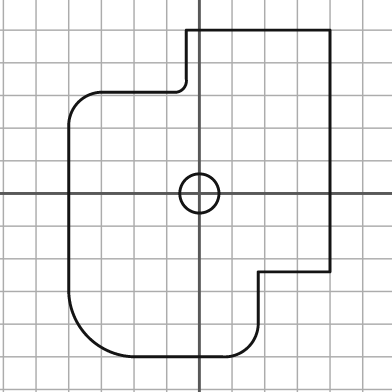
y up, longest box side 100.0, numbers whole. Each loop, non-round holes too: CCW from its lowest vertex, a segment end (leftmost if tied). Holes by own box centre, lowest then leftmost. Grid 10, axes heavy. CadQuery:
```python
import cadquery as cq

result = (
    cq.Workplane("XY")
    .moveTo(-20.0, -50.0)
    .lineTo(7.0, -50.0)
    .threePointArc((15.0, -47.0), (18.0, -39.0))
    .lineTo(18.0, -24.0)
    .lineTo(40.0, -24.0)
    .lineTo(40.0, 50.0)
    .lineTo(-4.0, 50.0)
    .lineTo(-4.0, 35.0)
    .threePointArc((-5.0, 32.0), (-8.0, 31.0))
    .lineTo(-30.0, 31.0)
    .threePointArc((-37.0, 28.0), (-40.0, 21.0))
    .lineTo(-40.0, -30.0)
    .threePointArc((-34.0, -44.0), (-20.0, -50.0))
    .close()
    .moveTo(0.0, 0.0)
    .circle(6.0)
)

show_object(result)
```